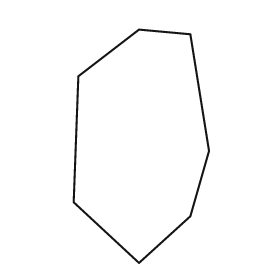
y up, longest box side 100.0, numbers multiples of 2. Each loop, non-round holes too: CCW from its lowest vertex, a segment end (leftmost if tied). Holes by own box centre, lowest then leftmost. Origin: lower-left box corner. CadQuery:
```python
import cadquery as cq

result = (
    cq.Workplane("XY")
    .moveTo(28.0, 0.0)
    .lineTo(50.0, 20.0)
    .lineTo(58.0, 48.0)
    .lineTo(50.0, 98.0)
    .lineTo(28.0, 100.0)
    .lineTo(2.0, 80.0)
    .lineTo(0.0, 26.0)
    .close()
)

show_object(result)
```